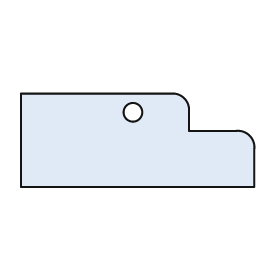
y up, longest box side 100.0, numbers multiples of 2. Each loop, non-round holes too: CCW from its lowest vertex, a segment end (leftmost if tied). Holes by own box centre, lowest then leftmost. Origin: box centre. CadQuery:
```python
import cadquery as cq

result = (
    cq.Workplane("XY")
    .moveTo(-50.0, -20.0)
    .lineTo(50.0, -20.0)
    .lineTo(50.0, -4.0)
    .threePointArc((48.0, 2.0), (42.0, 4.0))
    .lineTo(22.0, 4.0)
    .lineTo(22.0, 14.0)
    .threePointArc((20.0, 18.0), (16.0, 20.0))
    .lineTo(-50.0, 20.0)
    .close()
    .moveTo(-2.0, 12.0)
    .circle(4.0)
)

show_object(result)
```